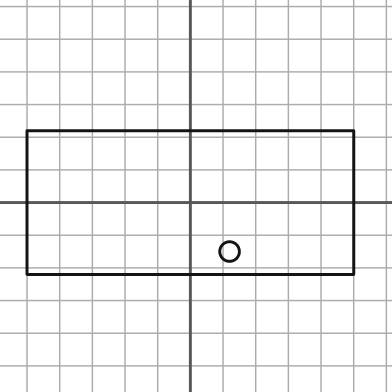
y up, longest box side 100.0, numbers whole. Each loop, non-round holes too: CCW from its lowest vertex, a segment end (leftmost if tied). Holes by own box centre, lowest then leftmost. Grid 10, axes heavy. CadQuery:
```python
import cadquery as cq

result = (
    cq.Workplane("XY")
    .moveTo(-50.0, -22.0)
    .lineTo(50.0, -22.0)
    .lineTo(50.0, 22.0)
    .lineTo(-50.0, 22.0)
    .close()
    .moveTo(12.0, -15.0)
    .circle(3.0)
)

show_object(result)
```